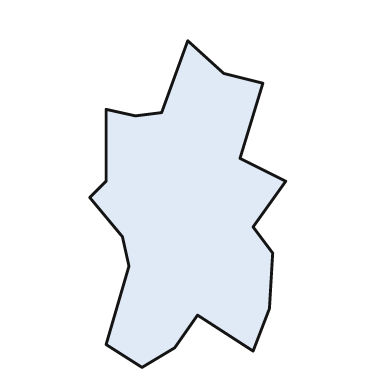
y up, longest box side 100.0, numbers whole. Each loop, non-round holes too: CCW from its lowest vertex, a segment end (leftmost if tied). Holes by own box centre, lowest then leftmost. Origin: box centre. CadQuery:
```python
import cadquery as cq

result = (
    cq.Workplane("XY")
    .moveTo(-14.0, -50.0)
    .lineTo(-4.0, -44.0)
    .lineTo(3.0, -34.0)
    .lineTo(20.0, -45.0)
    .lineTo(25.0, -32.0)
    .lineTo(26.0, -15.0)
    .lineTo(20.0, -7.0)
    .lineTo(30.0, 7.0)
    .lineTo(16.0, 14.0)
    .lineTo(23.0, 37.0)
    .lineTo(11.0, 40.0)
    .lineTo(0.0, 50.0)
    .lineTo(-8.0, 28.0)
    .lineTo(-16.0, 27.0)
    .lineTo(-25.0, 29.0)
    .lineTo(-25.0, 7.0)
    .lineTo(-30.0, 2.0)
    .lineTo(-20.0, -10.0)
    .lineTo(-18.0, -19.0)
    .lineTo(-25.0, -43.0)
    .close()
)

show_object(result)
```